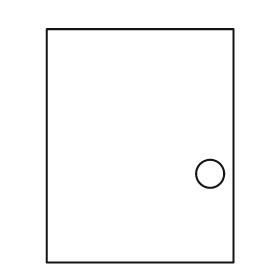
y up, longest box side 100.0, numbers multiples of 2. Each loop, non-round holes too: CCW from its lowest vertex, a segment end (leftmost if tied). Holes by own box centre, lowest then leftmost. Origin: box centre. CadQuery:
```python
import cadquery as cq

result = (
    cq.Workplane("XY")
    .moveTo(-40.0, -50.0)
    .lineTo(40.0, -50.0)
    .lineTo(40.0, 50.0)
    .lineTo(-40.0, 50.0)
    .close()
    .moveTo(30.0, -12.0)
    .circle(6.0)
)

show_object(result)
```